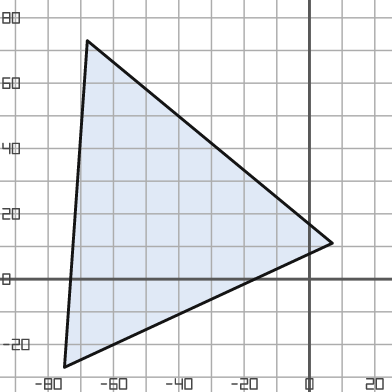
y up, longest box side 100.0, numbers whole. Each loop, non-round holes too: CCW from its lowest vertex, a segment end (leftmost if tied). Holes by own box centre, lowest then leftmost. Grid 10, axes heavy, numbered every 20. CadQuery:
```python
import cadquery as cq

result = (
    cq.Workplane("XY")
    .moveTo(-75.0, -27.0)
    .lineTo(7.0, 11.0)
    .lineTo(-68.0, 73.0)
    .close()
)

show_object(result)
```